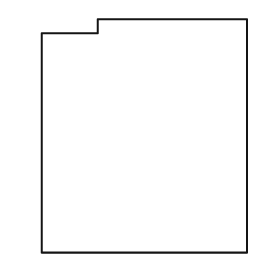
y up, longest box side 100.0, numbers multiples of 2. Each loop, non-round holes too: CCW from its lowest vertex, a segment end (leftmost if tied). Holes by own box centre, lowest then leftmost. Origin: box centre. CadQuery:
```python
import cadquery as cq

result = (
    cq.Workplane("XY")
    .moveTo(-44.0, -50.0)
    .lineTo(44.0, -50.0)
    .lineTo(44.0, 50.0)
    .lineTo(-20.0, 50.0)
    .lineTo(-20.0, 44.0)
    .lineTo(-44.0, 44.0)
    .close()
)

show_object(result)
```